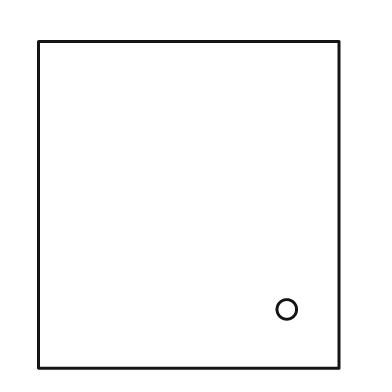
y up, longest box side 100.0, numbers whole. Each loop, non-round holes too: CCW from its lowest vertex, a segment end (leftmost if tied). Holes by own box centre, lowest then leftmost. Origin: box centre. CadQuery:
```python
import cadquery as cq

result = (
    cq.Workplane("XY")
    .moveTo(-46.0, -50.0)
    .lineTo(46.0, -50.0)
    .lineTo(46.0, 50.0)
    .lineTo(-46.0, 50.0)
    .close()
    .moveTo(30.0, -32.0)
    .circle(3.0)
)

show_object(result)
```